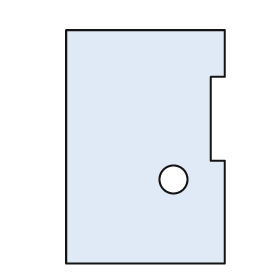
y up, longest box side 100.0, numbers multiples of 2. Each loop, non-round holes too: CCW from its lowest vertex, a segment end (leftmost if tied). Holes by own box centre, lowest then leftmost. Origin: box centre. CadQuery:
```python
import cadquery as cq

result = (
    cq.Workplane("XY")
    .moveTo(-34.0, -50.0)
    .lineTo(34.0, -50.0)
    .lineTo(34.0, -6.0)
    .lineTo(28.0, -6.0)
    .lineTo(28.0, 30.0)
    .lineTo(34.0, 30.0)
    .lineTo(34.0, 50.0)
    .lineTo(-34.0, 50.0)
    .close()
    .moveTo(12.0, -14.0)
    .circle(6.0)
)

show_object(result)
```